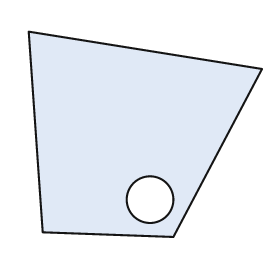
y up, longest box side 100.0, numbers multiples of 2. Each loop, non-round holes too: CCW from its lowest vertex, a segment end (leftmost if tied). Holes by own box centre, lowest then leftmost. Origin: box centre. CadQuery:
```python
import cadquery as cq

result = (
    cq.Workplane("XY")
    .moveTo(12.0, -44.0)
    .lineTo(50.0, 28.0)
    .lineTo(-50.0, 44.0)
    .lineTo(-44.0, -42.0)
    .close()
    .moveTo(2.0, -28.0)
    .circle(10.0)
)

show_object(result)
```